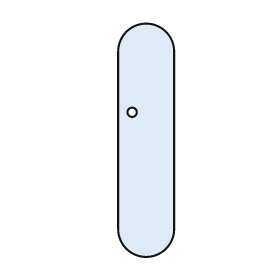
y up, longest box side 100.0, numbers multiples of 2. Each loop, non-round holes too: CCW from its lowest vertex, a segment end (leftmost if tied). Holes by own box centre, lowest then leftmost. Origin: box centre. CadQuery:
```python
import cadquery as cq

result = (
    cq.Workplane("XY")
    .moveTo(-12.0, -38.0)
    .threePointArc((0.0, -50.0), (12.0, -38.0))
    .lineTo(12.0, 38.0)
    .threePointArc((0.0, 50.0), (-12.0, 38.0))
    .close()
    .moveTo(-6.0, 12.0)
    .circle(2.0)
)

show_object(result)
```